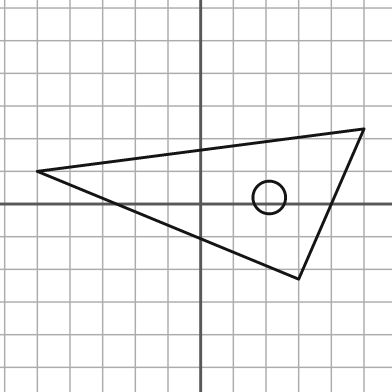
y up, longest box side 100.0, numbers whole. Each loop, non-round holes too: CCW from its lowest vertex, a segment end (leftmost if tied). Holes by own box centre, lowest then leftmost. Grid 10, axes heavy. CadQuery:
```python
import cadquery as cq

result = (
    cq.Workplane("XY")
    .moveTo(30.0, -23.0)
    .lineTo(50.0, 23.0)
    .lineTo(-50.0, 10.0)
    .close()
    .moveTo(21.0, 2.0)
    .circle(5.0)
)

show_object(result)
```